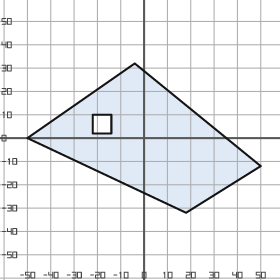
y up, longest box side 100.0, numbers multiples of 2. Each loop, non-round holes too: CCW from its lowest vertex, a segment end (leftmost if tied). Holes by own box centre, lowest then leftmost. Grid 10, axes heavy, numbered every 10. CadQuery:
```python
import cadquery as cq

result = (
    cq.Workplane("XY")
    .moveTo(18.0, -32.0)
    .lineTo(50.0, -12.0)
    .lineTo(-4.0, 32.0)
    .lineTo(-50.0, 0.0)
    .close()
    .moveTo(-22.0, 2.0)
    .lineTo(-14.0, 2.0)
    .lineTo(-14.0, 10.0)
    .lineTo(-22.0, 10.0)
    .close()
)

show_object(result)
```